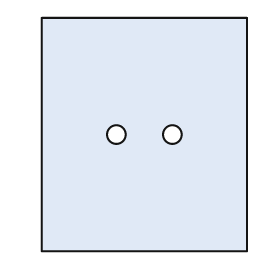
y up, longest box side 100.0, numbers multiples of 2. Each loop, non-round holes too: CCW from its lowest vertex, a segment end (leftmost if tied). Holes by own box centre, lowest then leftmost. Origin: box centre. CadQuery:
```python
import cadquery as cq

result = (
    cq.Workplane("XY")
    .moveTo(-44.0, -50.0)
    .lineTo(44.0, -50.0)
    .lineTo(44.0, 50.0)
    .lineTo(-44.0, 50.0)
    .close()
    .moveTo(-12.0, 0.0)
    .circle(4.0)
    .moveTo(12.0, 0.0)
    .circle(4.0)
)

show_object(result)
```